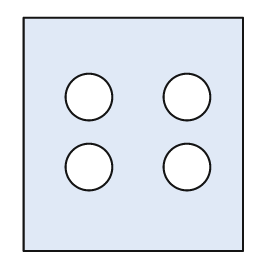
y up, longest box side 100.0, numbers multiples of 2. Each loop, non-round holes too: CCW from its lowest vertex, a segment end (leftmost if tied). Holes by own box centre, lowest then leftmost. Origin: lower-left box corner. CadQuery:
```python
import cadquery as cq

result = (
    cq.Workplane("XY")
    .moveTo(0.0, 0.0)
    .lineTo(94.0, 0.0)
    .lineTo(94.0, 100.0)
    .lineTo(0.0, 100.0)
    .close()
    .moveTo(28.0, 36.0)
    .circle(10.0)
    .moveTo(70.0, 36.0)
    .circle(10.0)
    .moveTo(28.0, 66.0)
    .circle(10.0)
    .moveTo(70.0, 66.0)
    .circle(10.0)
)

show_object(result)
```